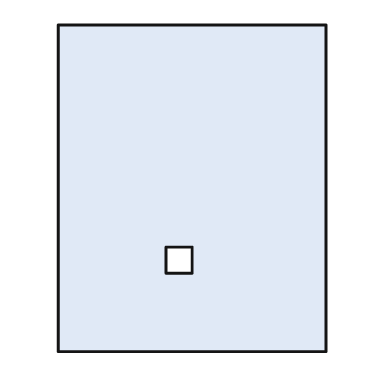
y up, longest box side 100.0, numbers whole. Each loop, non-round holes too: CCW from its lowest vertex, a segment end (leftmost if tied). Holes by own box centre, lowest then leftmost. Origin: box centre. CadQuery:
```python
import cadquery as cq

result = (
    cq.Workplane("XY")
    .moveTo(-41.0, -50.0)
    .lineTo(41.0, -50.0)
    .lineTo(41.0, 50.0)
    .lineTo(-41.0, 50.0)
    .close()
    .moveTo(-8.0, -26.0)
    .lineTo(0.0, -26.0)
    .lineTo(0.0, -18.0)
    .lineTo(-8.0, -18.0)
    .close()
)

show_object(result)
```